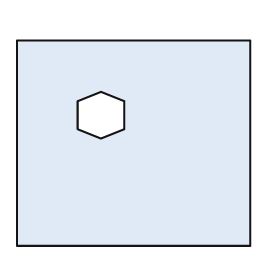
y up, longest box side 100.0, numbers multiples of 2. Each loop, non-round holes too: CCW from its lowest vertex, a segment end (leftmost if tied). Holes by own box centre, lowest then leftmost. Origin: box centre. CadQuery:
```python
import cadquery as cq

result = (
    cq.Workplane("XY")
    .moveTo(-50.0, -44.0)
    .lineTo(50.0, -44.0)
    .lineTo(50.0, 44.0)
    .lineTo(-50.0, 44.0)
    .close()
    .moveTo(-14.0, 2.0)
    .lineTo(-4.0, 6.0)
    .lineTo(-4.0, 18.0)
    .lineTo(-14.0, 22.0)
    .lineTo(-24.0, 18.0)
    .lineTo(-24.0, 6.0)
    .close()
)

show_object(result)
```